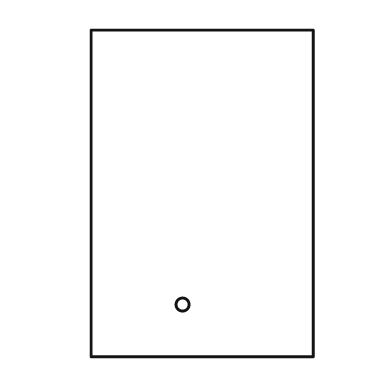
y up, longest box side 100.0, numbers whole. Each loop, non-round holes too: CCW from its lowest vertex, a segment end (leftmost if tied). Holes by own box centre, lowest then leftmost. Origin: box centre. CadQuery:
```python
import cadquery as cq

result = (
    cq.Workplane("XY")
    .moveTo(-34.0, -50.0)
    .lineTo(34.0, -50.0)
    .lineTo(34.0, 50.0)
    .lineTo(-34.0, 50.0)
    .close()
    .moveTo(-6.0, -34.0)
    .circle(2.0)
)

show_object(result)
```